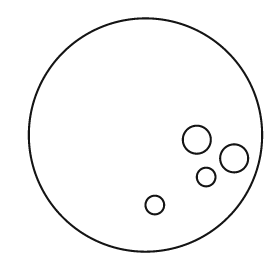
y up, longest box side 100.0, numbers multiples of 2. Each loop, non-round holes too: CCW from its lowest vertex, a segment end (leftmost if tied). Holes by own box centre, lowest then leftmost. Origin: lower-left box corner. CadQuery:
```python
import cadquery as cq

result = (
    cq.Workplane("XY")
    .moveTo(50.0, 50.0)
    .circle(50.0)
    .moveTo(54.0, 20.0)
    .circle(4.0)
    .moveTo(76.0, 32.0)
    .circle(4.0)
    .moveTo(88.0, 40.0)
    .circle(6.0)
    .moveTo(72.0, 48.0)
    .circle(6.0)
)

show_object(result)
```